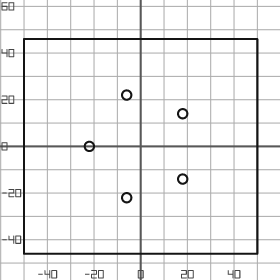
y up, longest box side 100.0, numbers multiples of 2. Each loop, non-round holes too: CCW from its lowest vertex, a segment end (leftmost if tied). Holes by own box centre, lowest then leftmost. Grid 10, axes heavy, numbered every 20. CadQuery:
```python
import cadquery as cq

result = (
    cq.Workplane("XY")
    .moveTo(-50.0, -46.0)
    .lineTo(50.0, -46.0)
    .lineTo(50.0, 46.0)
    .lineTo(-50.0, 46.0)
    .close()
    .moveTo(-6.0, -22.0)
    .circle(2.0)
    .moveTo(18.0, -14.0)
    .circle(2.0)
    .moveTo(-22.0, 0.0)
    .circle(2.0)
    .moveTo(18.0, 14.0)
    .circle(2.0)
    .moveTo(-6.0, 22.0)
    .circle(2.0)
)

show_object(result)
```